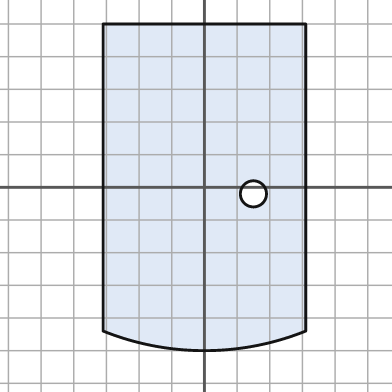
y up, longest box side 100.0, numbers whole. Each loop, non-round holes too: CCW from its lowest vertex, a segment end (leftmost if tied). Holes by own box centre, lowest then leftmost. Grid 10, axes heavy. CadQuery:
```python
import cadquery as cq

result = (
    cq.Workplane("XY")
    .moveTo(-31.0, -44.0)
    .threePointArc((0.0, -50.0), (31.0, -44.0))
    .lineTo(31.0, 50.0)
    .lineTo(-31.0, 50.0)
    .close()
    .moveTo(15.0, -2.0)
    .circle(4.0)
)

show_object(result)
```